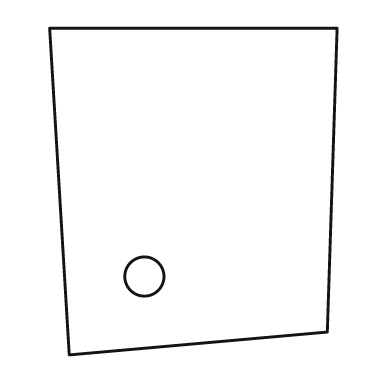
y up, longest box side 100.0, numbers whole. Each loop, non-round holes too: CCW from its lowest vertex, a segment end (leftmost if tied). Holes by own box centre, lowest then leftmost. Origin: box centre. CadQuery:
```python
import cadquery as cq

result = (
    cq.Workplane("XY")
    .moveTo(-38.0, -50.0)
    .lineTo(41.0, -43.0)
    .lineTo(44.0, 50.0)
    .lineTo(-44.0, 50.0)
    .close()
    .moveTo(-15.0, -26.0)
    .circle(6.0)
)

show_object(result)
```